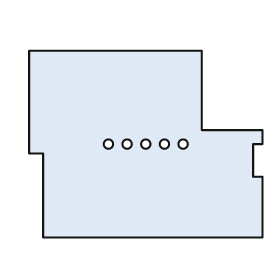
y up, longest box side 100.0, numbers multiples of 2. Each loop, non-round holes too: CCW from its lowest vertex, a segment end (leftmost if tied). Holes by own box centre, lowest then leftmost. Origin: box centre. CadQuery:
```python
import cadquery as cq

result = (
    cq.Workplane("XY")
    .moveTo(-44.0, -40.0)
    .lineTo(50.0, -40.0)
    .lineTo(50.0, -14.0)
    .lineTo(46.0, -14.0)
    .lineTo(46.0, 0.0)
    .lineTo(50.0, 0.0)
    .lineTo(50.0, 6.0)
    .lineTo(24.0, 6.0)
    .lineTo(24.0, 40.0)
    .lineTo(-50.0, 40.0)
    .lineTo(-50.0, -4.0)
    .lineTo(-44.0, -4.0)
    .close()
    .moveTo(-16.0, 0.0)
    .circle(2.0)
    .moveTo(-8.0, 0.0)
    .circle(2.0)
    .moveTo(0.0, 0.0)
    .circle(2.0)
    .moveTo(8.0, 0.0)
    .circle(2.0)
    .moveTo(16.0, 0.0)
    .circle(2.0)
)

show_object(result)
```